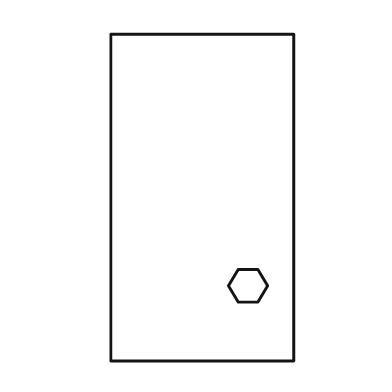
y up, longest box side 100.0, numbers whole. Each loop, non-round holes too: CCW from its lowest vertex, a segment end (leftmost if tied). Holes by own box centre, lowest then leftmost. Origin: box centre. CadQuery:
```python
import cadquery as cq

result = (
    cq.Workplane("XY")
    .moveTo(-28.0, -50.0)
    .lineTo(28.0, -50.0)
    .lineTo(28.0, 50.0)
    .lineTo(-28.0, 50.0)
    .close()
    .moveTo(11.0, -32.0)
    .lineTo(17.0, -32.0)
    .lineTo(20.0, -27.0)
    .lineTo(17.0, -22.0)
    .lineTo(11.0, -22.0)
    .lineTo(8.0, -27.0)
    .close()
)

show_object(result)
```